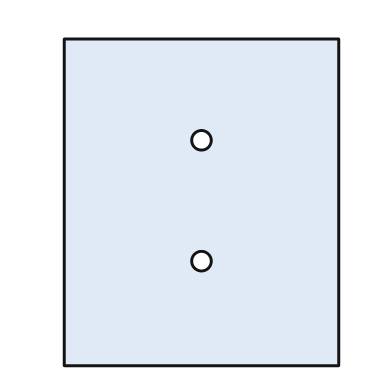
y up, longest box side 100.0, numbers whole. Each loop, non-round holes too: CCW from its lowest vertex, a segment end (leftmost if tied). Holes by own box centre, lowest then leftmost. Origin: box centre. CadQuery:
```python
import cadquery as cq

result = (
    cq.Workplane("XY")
    .moveTo(-42.0, -50.0)
    .lineTo(42.0, -50.0)
    .lineTo(42.0, 50.0)
    .lineTo(-42.0, 50.0)
    .close()
    .moveTo(0.0, -18.0)
    .circle(3.0)
    .moveTo(0.0, 19.0)
    .circle(3.0)
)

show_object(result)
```